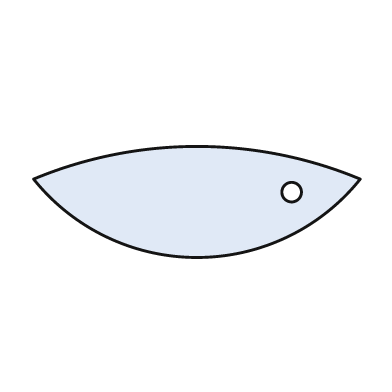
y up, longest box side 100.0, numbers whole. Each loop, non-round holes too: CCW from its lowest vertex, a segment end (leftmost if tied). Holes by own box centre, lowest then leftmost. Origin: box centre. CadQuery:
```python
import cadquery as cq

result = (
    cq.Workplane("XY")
    .moveTo(-50.0, 7.0)
    .threePointArc((0.0, -17.0), (50.0, 7.0))
    .threePointArc((0.0, 17.0), (-50.0, 7.0))
    .close()
    .moveTo(29.0, 3.0)
    .circle(3.0)
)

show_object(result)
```